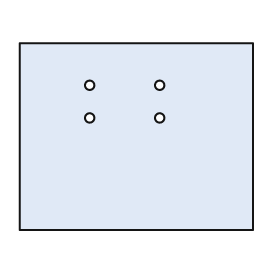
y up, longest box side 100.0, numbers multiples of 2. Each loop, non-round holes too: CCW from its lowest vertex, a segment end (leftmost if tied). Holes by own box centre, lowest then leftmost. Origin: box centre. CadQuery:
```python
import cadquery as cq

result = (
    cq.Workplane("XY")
    .moveTo(-50.0, -40.0)
    .lineTo(50.0, -40.0)
    .lineTo(50.0, 40.0)
    .lineTo(-50.0, 40.0)
    .close()
    .moveTo(-20.0, 8.0)
    .circle(2.0)
    .moveTo(10.0, 8.0)
    .circle(2.0)
    .moveTo(-20.0, 22.0)
    .circle(2.0)
    .moveTo(10.0, 22.0)
    .circle(2.0)
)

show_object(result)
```